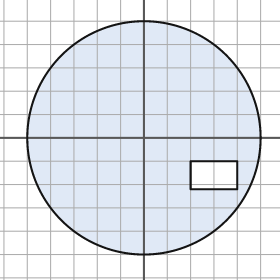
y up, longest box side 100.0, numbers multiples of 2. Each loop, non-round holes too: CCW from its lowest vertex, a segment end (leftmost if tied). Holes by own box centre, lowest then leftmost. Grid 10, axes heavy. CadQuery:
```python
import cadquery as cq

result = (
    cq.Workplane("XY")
    .moveTo(0.0, 0.0)
    .circle(50.0)
    .moveTo(20.0, -22.0)
    .lineTo(40.0, -22.0)
    .lineTo(40.0, -10.0)
    .lineTo(20.0, -10.0)
    .close()
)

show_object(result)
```